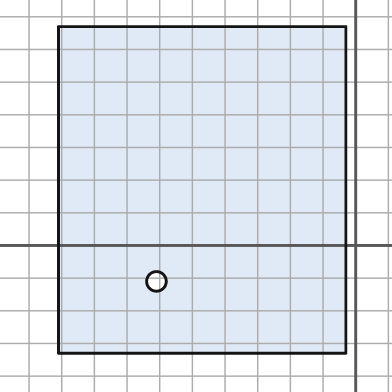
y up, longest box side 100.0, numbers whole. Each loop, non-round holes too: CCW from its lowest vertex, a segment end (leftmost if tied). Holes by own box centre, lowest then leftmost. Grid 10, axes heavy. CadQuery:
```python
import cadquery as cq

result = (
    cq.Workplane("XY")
    .moveTo(-91.0, -33.0)
    .lineTo(-3.0, -33.0)
    .lineTo(-3.0, 67.0)
    .lineTo(-91.0, 67.0)
    .close()
    .moveTo(-61.0, -11.0)
    .circle(3.0)
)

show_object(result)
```